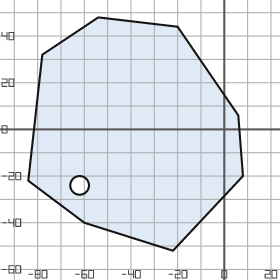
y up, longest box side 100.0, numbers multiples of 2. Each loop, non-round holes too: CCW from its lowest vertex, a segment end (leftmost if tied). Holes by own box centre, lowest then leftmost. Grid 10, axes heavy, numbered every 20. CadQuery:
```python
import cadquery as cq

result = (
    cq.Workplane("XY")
    .moveTo(-22.0, -52.0)
    .lineTo(8.0, -20.0)
    .lineTo(6.0, 6.0)
    .lineTo(-20.0, 44.0)
    .lineTo(-54.0, 48.0)
    .lineTo(-78.0, 32.0)
    .lineTo(-84.0, -22.0)
    .lineTo(-60.0, -40.0)
    .close()
    .moveTo(-62.0, -24.0)
    .circle(4.0)
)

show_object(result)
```